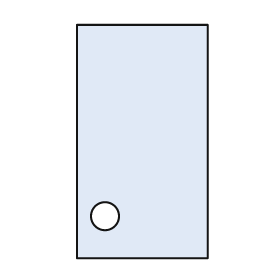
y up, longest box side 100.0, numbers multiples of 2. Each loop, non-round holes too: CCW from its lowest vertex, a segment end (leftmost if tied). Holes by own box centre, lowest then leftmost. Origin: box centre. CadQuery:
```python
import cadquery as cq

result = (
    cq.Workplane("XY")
    .moveTo(-28.0, -50.0)
    .lineTo(28.0, -50.0)
    .lineTo(28.0, 50.0)
    .lineTo(-28.0, 50.0)
    .close()
    .moveTo(-16.0, -32.0)
    .circle(6.0)
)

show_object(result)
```